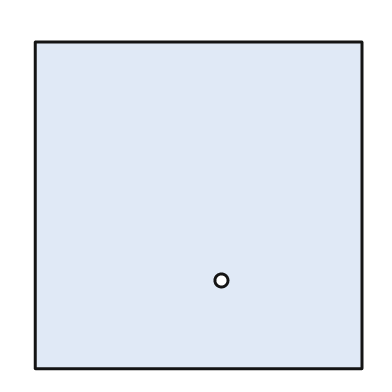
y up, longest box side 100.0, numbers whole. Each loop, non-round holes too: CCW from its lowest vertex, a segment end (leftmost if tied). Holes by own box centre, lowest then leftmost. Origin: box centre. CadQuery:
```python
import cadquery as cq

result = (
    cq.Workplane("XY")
    .moveTo(-50.0, -50.0)
    .lineTo(50.0, -50.0)
    .lineTo(50.0, 50.0)
    .lineTo(-50.0, 50.0)
    .close()
    .moveTo(7.0, -23.0)
    .circle(2.0)
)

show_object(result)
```